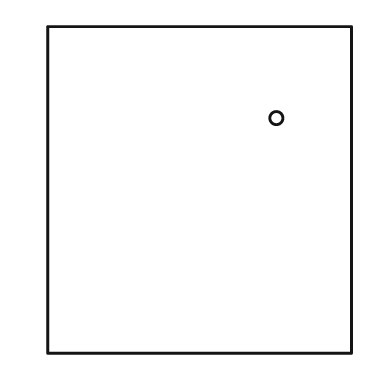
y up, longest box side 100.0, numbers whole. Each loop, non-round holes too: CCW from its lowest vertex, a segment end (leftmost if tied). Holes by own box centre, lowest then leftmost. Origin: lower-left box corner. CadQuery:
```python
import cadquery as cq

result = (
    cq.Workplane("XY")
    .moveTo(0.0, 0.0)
    .lineTo(93.0, 0.0)
    .lineTo(93.0, 100.0)
    .lineTo(0.0, 100.0)
    .close()
    .moveTo(70.0, 72.0)
    .circle(2.0)
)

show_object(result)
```